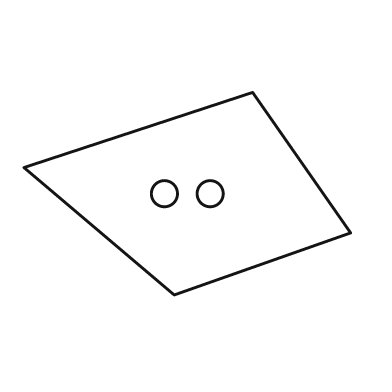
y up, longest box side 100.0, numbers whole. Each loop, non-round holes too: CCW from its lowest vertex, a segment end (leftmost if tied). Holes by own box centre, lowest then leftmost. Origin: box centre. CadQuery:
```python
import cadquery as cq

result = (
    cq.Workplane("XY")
    .moveTo(-4.0, -31.0)
    .lineTo(50.0, -12.0)
    .lineTo(20.0, 31.0)
    .lineTo(-50.0, 8.0)
    .close()
    .moveTo(-7.0, 0.0)
    .circle(4.0)
    .moveTo(7.0, 0.0)
    .circle(4.0)
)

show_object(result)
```